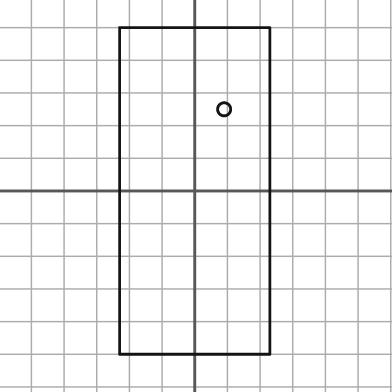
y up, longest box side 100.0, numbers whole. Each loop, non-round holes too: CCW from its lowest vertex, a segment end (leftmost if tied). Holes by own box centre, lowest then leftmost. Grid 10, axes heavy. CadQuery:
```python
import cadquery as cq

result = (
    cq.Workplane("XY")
    .moveTo(-23.0, -50.0)
    .lineTo(23.0, -50.0)
    .lineTo(23.0, 50.0)
    .lineTo(-23.0, 50.0)
    .close()
    .moveTo(9.0, 25.0)
    .circle(2.0)
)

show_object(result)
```